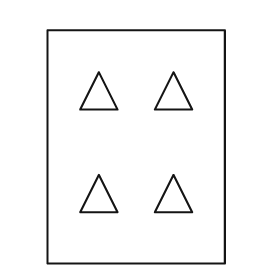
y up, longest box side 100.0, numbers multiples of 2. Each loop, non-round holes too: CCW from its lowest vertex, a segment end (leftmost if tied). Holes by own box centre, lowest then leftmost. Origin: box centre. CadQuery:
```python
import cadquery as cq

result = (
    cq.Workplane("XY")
    .moveTo(-38.0, -50.0)
    .lineTo(38.0, -50.0)
    .lineTo(38.0, 50.0)
    .lineTo(-38.0, 50.0)
    .close()
    .moveTo(-24.0, -28.0)
    .lineTo(-8.0, -28.0)
    .lineTo(-16.0, -12.0)
    .close()
    .moveTo(8.0, -28.0)
    .lineTo(24.0, -28.0)
    .lineTo(16.0, -12.0)
    .close()
    .moveTo(-24.0, 16.0)
    .lineTo(-8.0, 16.0)
    .lineTo(-16.0, 32.0)
    .close()
    .moveTo(8.0, 16.0)
    .lineTo(24.0, 16.0)
    .lineTo(16.0, 32.0)
    .close()
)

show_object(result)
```